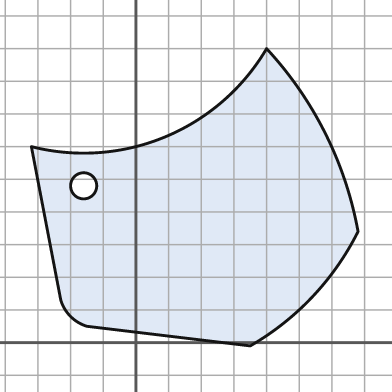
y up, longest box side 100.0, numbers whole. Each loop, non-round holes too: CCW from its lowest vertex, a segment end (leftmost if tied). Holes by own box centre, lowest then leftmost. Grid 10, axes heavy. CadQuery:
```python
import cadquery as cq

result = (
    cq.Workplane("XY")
    .moveTo(35.0, -1.0)
    .threePointArc((54.0, 14.0), (68.0, 34.0))
    .threePointArc((58.0, 64.0), (40.0, 90.0))
    .threePointArc((9.0, 63.0), (-32.0, 60.0))
    .lineTo(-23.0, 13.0)
    .threePointArc((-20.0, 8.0), (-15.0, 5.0))
    .close()
    .moveTo(-16.0, 48.0)
    .circle(4.0)
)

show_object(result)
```